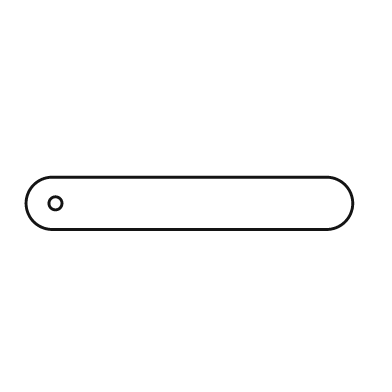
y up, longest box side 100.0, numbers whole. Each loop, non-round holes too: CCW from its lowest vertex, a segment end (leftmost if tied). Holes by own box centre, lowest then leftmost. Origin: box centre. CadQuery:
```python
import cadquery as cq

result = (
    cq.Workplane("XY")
    .moveTo(-42.0, -8.0)
    .lineTo(42.0, -8.0)
    .threePointArc((50.0, 0.0), (42.0, 8.0))
    .lineTo(-42.0, 8.0)
    .threePointArc((-50.0, 0.0), (-42.0, -8.0))
    .close()
    .moveTo(-41.0, 0.0)
    .circle(2.0)
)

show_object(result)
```